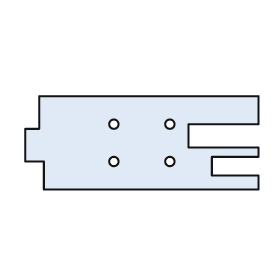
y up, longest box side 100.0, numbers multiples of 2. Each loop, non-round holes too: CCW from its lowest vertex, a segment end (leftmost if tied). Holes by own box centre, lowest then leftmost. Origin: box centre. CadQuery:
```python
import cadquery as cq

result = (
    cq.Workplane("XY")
    .moveTo(-42.0, -20.0)
    .lineTo(50.0, -20.0)
    .lineTo(50.0, -14.0)
    .lineTo(30.0, -14.0)
    .lineTo(30.0, -6.0)
    .lineTo(50.0, -6.0)
    .lineTo(50.0, -2.0)
    .lineTo(20.0, -2.0)
    .lineTo(20.0, 8.0)
    .lineTo(50.0, 8.0)
    .lineTo(50.0, 20.0)
    .lineTo(-44.0, 20.0)
    .lineTo(-44.0, 6.0)
    .lineTo(-50.0, 6.0)
    .lineTo(-50.0, -8.0)
    .lineTo(-42.0, -8.0)
    .close()
    .moveTo(-12.0, -8.0)
    .circle(2.0)
    .moveTo(12.0, -8.0)
    .circle(2.0)
    .moveTo(-12.0, 8.0)
    .circle(2.0)
    .moveTo(12.0, 8.0)
    .circle(2.0)
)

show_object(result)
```